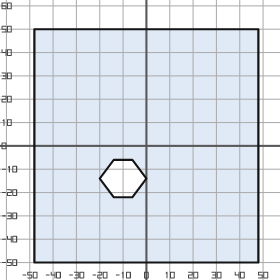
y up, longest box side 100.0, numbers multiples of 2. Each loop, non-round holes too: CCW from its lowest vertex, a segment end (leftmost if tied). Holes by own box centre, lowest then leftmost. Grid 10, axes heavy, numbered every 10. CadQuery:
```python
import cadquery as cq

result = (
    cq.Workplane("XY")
    .moveTo(-48.0, -50.0)
    .lineTo(48.0, -50.0)
    .lineTo(48.0, 50.0)
    .lineTo(-48.0, 50.0)
    .close()
    .moveTo(-14.0, -22.0)
    .lineTo(-6.0, -22.0)
    .lineTo(0.0, -14.0)
    .lineTo(-6.0, -6.0)
    .lineTo(-14.0, -6.0)
    .lineTo(-20.0, -14.0)
    .close()
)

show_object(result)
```